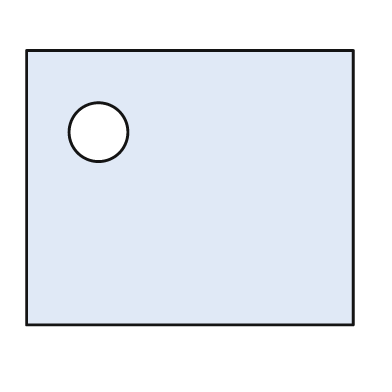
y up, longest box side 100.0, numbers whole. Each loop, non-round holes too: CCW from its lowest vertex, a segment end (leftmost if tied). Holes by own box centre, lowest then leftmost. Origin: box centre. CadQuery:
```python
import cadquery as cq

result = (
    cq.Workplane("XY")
    .moveTo(-50.0, -42.0)
    .lineTo(50.0, -42.0)
    .lineTo(50.0, 42.0)
    .lineTo(-50.0, 42.0)
    .close()
    .moveTo(-28.0, 17.0)
    .circle(9.0)
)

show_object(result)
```